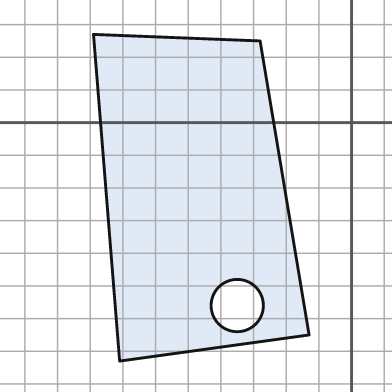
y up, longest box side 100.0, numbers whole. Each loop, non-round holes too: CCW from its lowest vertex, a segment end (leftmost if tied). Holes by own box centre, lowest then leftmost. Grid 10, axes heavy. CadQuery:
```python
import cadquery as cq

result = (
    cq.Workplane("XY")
    .moveTo(-71.0, -73.0)
    .lineTo(-13.0, -65.0)
    .lineTo(-28.0, 25.0)
    .lineTo(-79.0, 27.0)
    .close()
    .moveTo(-35.0, -56.0)
    .circle(8.0)
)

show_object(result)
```